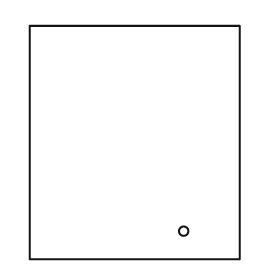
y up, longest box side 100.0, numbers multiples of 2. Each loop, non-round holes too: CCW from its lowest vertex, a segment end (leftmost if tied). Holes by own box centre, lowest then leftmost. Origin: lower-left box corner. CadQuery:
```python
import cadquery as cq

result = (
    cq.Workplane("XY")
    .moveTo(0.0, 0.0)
    .lineTo(90.0, 0.0)
    .lineTo(90.0, 100.0)
    .lineTo(0.0, 100.0)
    .close()
    .moveTo(66.0, 12.0)
    .circle(2.0)
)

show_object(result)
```